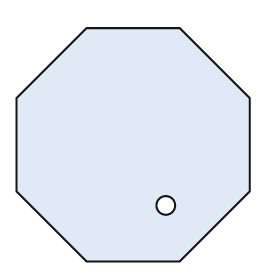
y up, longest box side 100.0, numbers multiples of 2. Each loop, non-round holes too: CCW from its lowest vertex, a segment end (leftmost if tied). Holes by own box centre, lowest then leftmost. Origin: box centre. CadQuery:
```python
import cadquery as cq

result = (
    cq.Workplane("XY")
    .moveTo(-20.0, -50.0)
    .lineTo(20.0, -50.0)
    .lineTo(50.0, -20.0)
    .lineTo(50.0, 20.0)
    .lineTo(20.0, 50.0)
    .lineTo(-20.0, 50.0)
    .lineTo(-50.0, 20.0)
    .lineTo(-50.0, -20.0)
    .close()
    .moveTo(14.0, -26.0)
    .circle(4.0)
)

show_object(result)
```